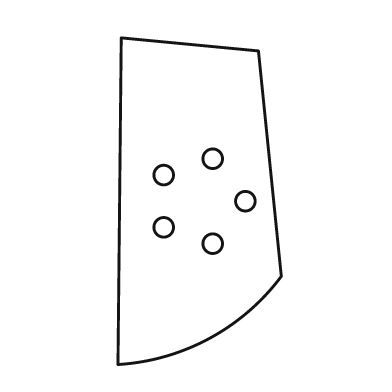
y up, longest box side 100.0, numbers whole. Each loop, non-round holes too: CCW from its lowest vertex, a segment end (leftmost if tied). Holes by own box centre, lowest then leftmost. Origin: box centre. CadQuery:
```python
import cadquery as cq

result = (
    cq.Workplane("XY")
    .moveTo(-25.0, -50.0)
    .threePointArc((3.0, -42.0), (25.0, -23.0))
    .lineTo(18.0, 46.0)
    .lineTo(-24.0, 50.0)
    .close()
    .moveTo(4.0, -13.0)
    .circle(3.0)
    .moveTo(-11.0, -8.0)
    .circle(3.0)
    .moveTo(14.0, 0.0)
    .circle(3.0)
    .moveTo(-11.0, 8.0)
    .circle(3.0)
    .moveTo(4.0, 13.0)
    .circle(3.0)
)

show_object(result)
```